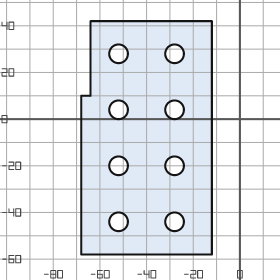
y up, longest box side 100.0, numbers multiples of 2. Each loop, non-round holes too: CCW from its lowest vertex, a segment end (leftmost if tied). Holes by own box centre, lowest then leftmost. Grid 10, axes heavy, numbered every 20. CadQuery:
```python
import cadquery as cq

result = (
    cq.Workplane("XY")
    .moveTo(-68.0, -58.0)
    .lineTo(-12.0, -58.0)
    .lineTo(-12.0, 42.0)
    .lineTo(-64.0, 42.0)
    .lineTo(-64.0, 10.0)
    .lineTo(-68.0, 10.0)
    .close()
    .moveTo(-52.0, -44.0)
    .circle(4.0)
    .moveTo(-28.0, -44.0)
    .circle(4.0)
    .moveTo(-52.0, -20.0)
    .circle(4.0)
    .moveTo(-28.0, -20.0)
    .circle(4.0)
    .moveTo(-52.0, 4.0)
    .circle(4.0)
    .moveTo(-28.0, 4.0)
    .circle(4.0)
    .moveTo(-52.0, 28.0)
    .circle(4.0)
    .moveTo(-28.0, 28.0)
    .circle(4.0)
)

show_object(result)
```